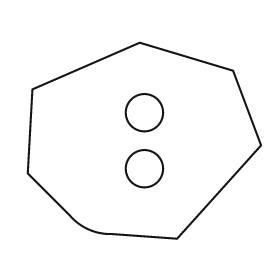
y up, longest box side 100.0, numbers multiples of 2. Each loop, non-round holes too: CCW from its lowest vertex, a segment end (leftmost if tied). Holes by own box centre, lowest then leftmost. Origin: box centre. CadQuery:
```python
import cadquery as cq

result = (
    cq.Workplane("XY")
    .moveTo(14.0, -42.0)
    .lineTo(50.0, -2.0)
    .lineTo(38.0, 30.0)
    .lineTo(-2.0, 42.0)
    .lineTo(-48.0, 22.0)
    .lineTo(-50.0, -14.0)
    .lineTo(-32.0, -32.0)
    .threePointArc((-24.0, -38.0), (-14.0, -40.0))
    .close()
    .moveTo(0.0, -12.0)
    .circle(8.0)
    .moveTo(0.0, 12.0)
    .circle(8.0)
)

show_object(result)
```